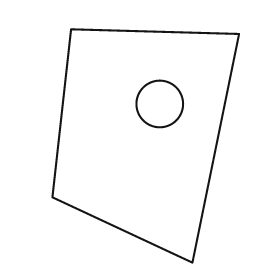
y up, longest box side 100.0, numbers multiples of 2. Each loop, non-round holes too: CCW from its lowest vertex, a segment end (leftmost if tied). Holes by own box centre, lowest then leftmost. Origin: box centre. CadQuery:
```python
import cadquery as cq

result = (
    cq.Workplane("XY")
    .moveTo(20.0, -50.0)
    .lineTo(40.0, 48.0)
    .lineTo(-32.0, 50.0)
    .lineTo(-40.0, -22.0)
    .close()
    .moveTo(6.0, 18.0)
    .circle(10.0)
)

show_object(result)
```